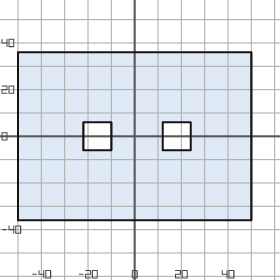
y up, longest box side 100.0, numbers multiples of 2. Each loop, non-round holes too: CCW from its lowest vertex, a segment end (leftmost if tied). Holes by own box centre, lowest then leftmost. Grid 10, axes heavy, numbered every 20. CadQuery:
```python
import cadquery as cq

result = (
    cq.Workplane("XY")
    .moveTo(-50.0, -36.0)
    .lineTo(50.0, -36.0)
    .lineTo(50.0, 36.0)
    .lineTo(-50.0, 36.0)
    .close()
    .moveTo(-22.0, -6.0)
    .lineTo(-10.0, -6.0)
    .lineTo(-10.0, 6.0)
    .lineTo(-22.0, 6.0)
    .close()
    .moveTo(12.0, -6.0)
    .lineTo(24.0, -6.0)
    .lineTo(24.0, 6.0)
    .lineTo(12.0, 6.0)
    .close()
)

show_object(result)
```